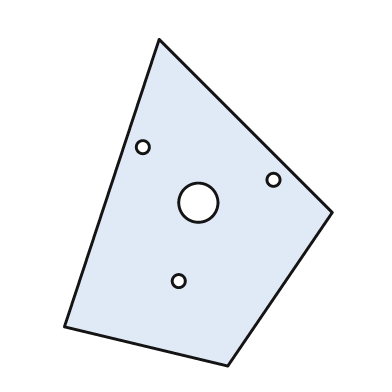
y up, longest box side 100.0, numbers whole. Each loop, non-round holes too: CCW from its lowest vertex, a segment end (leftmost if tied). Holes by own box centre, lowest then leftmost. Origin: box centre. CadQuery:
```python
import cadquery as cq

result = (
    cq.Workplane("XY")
    .moveTo(9.0, -50.0)
    .lineTo(41.0, -3.0)
    .lineTo(-12.0, 50.0)
    .lineTo(-41.0, -38.0)
    .close()
    .moveTo(-6.0, -24.0)
    .circle(2.0)
    .moveTo(0.0, 0.0)
    .circle(6.0)
    .moveTo(23.0, 7.0)
    .circle(2.0)
    .moveTo(-17.0, 17.0)
    .circle(2.0)
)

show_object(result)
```